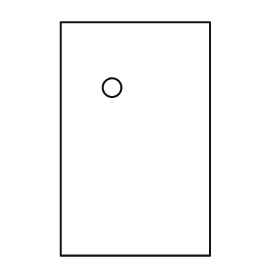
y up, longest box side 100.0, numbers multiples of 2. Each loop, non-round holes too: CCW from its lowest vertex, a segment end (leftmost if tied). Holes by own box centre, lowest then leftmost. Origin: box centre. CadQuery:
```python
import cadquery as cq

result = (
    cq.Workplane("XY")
    .moveTo(-32.0, -50.0)
    .lineTo(32.0, -50.0)
    .lineTo(32.0, 50.0)
    .lineTo(-32.0, 50.0)
    .close()
    .moveTo(-10.0, 22.0)
    .circle(4.0)
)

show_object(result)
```